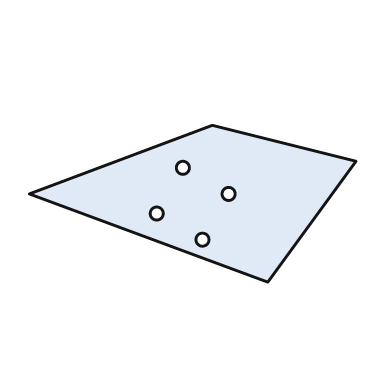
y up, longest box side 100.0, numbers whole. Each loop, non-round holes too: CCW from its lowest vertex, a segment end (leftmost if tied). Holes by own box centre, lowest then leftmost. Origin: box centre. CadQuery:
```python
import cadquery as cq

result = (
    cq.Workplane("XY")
    .moveTo(23.0, -24.0)
    .lineTo(50.0, 13.0)
    .lineTo(6.0, 24.0)
    .lineTo(-50.0, 3.0)
    .close()
    .moveTo(3.0, -11.0)
    .circle(2.0)
    .moveTo(-11.0, -3.0)
    .circle(2.0)
    .moveTo(11.0, 3.0)
    .circle(2.0)
    .moveTo(-3.0, 11.0)
    .circle(2.0)
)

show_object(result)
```